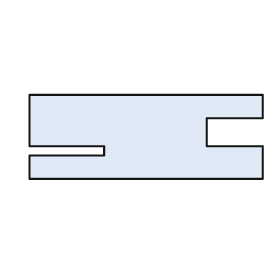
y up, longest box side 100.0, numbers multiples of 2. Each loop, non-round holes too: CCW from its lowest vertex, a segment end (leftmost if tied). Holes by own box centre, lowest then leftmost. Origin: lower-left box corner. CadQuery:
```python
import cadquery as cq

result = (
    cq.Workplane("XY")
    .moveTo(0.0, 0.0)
    .lineTo(100.0, 0.0)
    .lineTo(100.0, 14.0)
    .lineTo(76.0, 14.0)
    .lineTo(76.0, 26.0)
    .lineTo(100.0, 26.0)
    .lineTo(100.0, 36.0)
    .lineTo(0.0, 36.0)
    .lineTo(0.0, 14.0)
    .lineTo(32.0, 14.0)
    .lineTo(32.0, 10.0)
    .lineTo(0.0, 10.0)
    .close()
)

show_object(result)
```